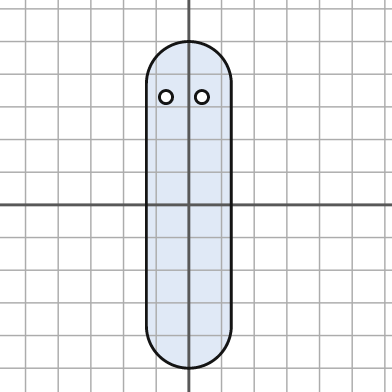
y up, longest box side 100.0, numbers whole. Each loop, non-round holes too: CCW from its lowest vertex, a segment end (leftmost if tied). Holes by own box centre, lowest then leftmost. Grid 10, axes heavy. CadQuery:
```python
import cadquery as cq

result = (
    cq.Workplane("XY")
    .moveTo(-13.0, -37.0)
    .threePointArc((0.0, -50.0), (13.0, -37.0))
    .lineTo(13.0, 37.0)
    .threePointArc((0.0, 50.0), (-13.0, 37.0))
    .close()
    .moveTo(-7.0, 33.0)
    .circle(2.0)
    .moveTo(4.0, 33.0)
    .circle(2.0)
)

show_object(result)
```